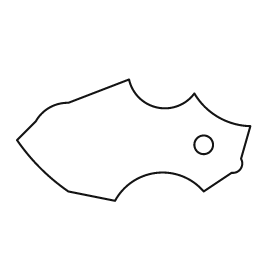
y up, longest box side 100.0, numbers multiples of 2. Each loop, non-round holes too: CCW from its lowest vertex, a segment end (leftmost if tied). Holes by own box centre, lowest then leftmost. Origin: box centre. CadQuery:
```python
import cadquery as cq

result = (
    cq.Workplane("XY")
    .moveTo(-8.0, -26.0)
    .threePointArc((10.0, -14.0), (30.0, -22.0))
    .lineTo(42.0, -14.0)
    .threePointArc((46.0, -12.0), (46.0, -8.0))
    .lineTo(50.0, 6.0)
    .threePointArc((36.0, 10.0), (26.0, 20.0))
    .threePointArc((10.0, 14.0), (-2.0, 26.0))
    .lineTo(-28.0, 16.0)
    .threePointArc((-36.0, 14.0), (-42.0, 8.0))
    .lineTo(-50.0, 0.0)
    .threePointArc((-40.0, -12.0), (-28.0, -22.0))
    .close()
    .moveTo(30.0, -2.0)
    .circle(4.0)
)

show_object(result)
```